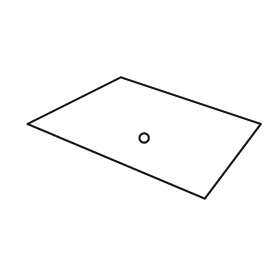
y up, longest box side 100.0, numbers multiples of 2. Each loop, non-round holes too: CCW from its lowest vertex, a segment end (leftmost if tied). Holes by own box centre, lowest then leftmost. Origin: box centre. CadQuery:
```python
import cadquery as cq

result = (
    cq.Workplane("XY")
    .moveTo(26.0, -26.0)
    .lineTo(50.0, 6.0)
    .lineTo(-10.0, 26.0)
    .lineTo(-50.0, 6.0)
    .close()
    .moveTo(0.0, 0.0)
    .circle(2.0)
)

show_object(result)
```